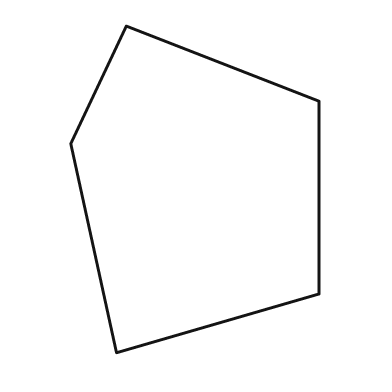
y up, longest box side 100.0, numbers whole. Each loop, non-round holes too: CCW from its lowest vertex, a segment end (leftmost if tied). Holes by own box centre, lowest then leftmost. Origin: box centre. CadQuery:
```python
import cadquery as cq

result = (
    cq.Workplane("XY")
    .moveTo(-24.0, -50.0)
    .lineTo(38.0, -32.0)
    .lineTo(38.0, 27.0)
    .lineTo(-21.0, 50.0)
    .lineTo(-38.0, 14.0)
    .close()
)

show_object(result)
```